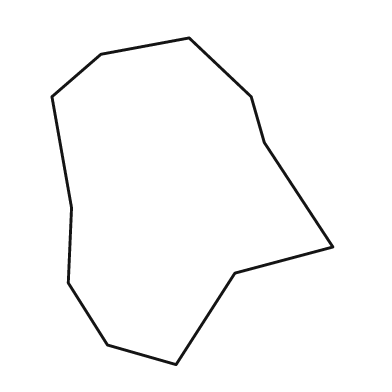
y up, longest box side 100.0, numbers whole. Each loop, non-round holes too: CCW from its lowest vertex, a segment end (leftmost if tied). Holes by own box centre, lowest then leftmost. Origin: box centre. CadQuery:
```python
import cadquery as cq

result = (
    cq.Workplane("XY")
    .moveTo(-5.0, -50.0)
    .lineTo(13.0, -22.0)
    .lineTo(43.0, -14.0)
    .lineTo(22.0, 18.0)
    .lineTo(18.0, 32.0)
    .lineTo(-1.0, 50.0)
    .lineTo(-28.0, 45.0)
    .lineTo(-43.0, 32.0)
    .lineTo(-37.0, -2.0)
    .lineTo(-38.0, -25.0)
    .lineTo(-26.0, -44.0)
    .close()
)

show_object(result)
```